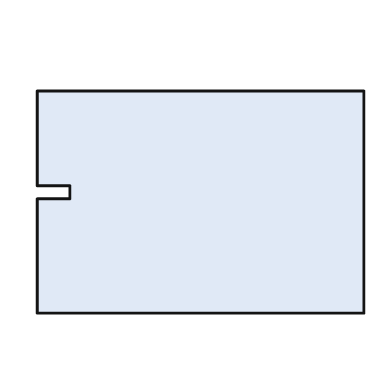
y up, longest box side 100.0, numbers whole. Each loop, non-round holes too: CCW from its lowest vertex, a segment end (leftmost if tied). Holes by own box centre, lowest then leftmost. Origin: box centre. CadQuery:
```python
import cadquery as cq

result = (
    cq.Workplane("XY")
    .moveTo(-50.0, -34.0)
    .lineTo(50.0, -34.0)
    .lineTo(50.0, 34.0)
    .lineTo(-50.0, 34.0)
    .lineTo(-50.0, 5.0)
    .lineTo(-40.0, 5.0)
    .lineTo(-40.0, 1.0)
    .lineTo(-50.0, 1.0)
    .close()
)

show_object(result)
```